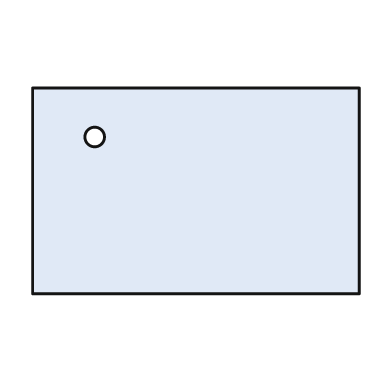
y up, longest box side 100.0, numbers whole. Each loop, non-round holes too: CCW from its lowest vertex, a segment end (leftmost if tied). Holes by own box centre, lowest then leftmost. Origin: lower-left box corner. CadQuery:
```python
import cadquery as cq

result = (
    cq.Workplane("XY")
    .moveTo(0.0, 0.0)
    .lineTo(100.0, 0.0)
    .lineTo(100.0, 63.0)
    .lineTo(0.0, 63.0)
    .close()
    .moveTo(19.0, 48.0)
    .circle(3.0)
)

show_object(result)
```